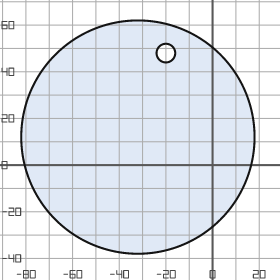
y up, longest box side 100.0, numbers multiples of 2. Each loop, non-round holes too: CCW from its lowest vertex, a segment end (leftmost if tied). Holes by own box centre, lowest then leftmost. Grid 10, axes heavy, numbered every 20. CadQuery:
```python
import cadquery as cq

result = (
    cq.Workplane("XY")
    .moveTo(-32.0, 12.0)
    .circle(50.0)
    .moveTo(-20.0, 48.0)
    .circle(4.0)
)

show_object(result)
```